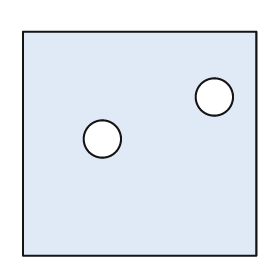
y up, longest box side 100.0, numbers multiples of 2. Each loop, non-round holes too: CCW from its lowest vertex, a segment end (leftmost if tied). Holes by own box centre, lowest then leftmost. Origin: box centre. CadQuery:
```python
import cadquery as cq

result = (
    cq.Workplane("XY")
    .moveTo(-50.0, -48.0)
    .lineTo(50.0, -48.0)
    .lineTo(50.0, 48.0)
    .lineTo(-50.0, 48.0)
    .close()
    .moveTo(-16.0, 2.0)
    .circle(8.0)
    .moveTo(32.0, 20.0)
    .circle(8.0)
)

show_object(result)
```